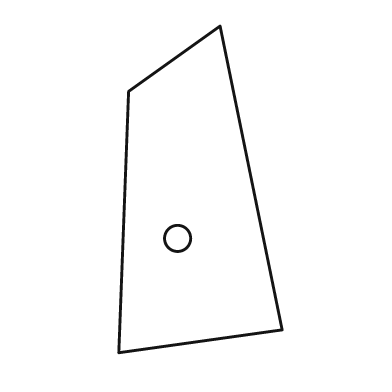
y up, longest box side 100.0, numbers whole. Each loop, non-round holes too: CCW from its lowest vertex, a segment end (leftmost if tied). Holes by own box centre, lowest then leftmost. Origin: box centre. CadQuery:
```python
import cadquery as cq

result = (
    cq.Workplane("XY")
    .moveTo(-25.0, -50.0)
    .lineTo(25.0, -43.0)
    .lineTo(6.0, 50.0)
    .lineTo(-22.0, 30.0)
    .close()
    .moveTo(-7.0, -15.0)
    .circle(4.0)
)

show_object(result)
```